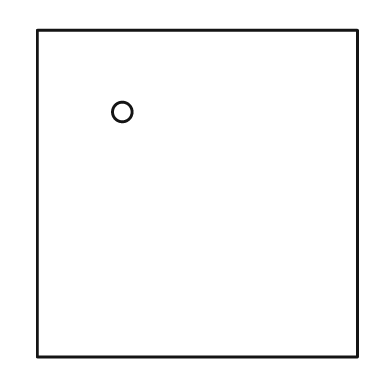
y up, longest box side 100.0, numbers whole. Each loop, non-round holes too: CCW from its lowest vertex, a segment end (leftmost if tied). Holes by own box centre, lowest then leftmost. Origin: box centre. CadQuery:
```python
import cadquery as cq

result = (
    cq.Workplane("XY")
    .moveTo(-49.0, -50.0)
    .lineTo(49.0, -50.0)
    .lineTo(49.0, 50.0)
    .lineTo(-49.0, 50.0)
    .close()
    .moveTo(-23.0, 25.0)
    .circle(3.0)
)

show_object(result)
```